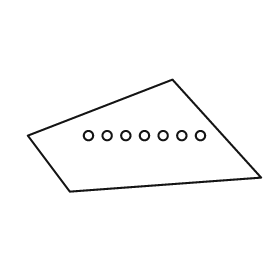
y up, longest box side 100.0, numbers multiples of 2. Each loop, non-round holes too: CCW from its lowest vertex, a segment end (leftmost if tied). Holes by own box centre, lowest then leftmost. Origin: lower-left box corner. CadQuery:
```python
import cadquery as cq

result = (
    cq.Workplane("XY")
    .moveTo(18.0, 0.0)
    .lineTo(100.0, 6.0)
    .lineTo(62.0, 48.0)
    .lineTo(0.0, 24.0)
    .close()
    .moveTo(26.0, 24.0)
    .circle(2.0)
    .moveTo(34.0, 24.0)
    .circle(2.0)
    .moveTo(42.0, 24.0)
    .circle(2.0)
    .moveTo(50.0, 24.0)
    .circle(2.0)
    .moveTo(58.0, 24.0)
    .circle(2.0)
    .moveTo(66.0, 24.0)
    .circle(2.0)
    .moveTo(74.0, 24.0)
    .circle(2.0)
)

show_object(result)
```